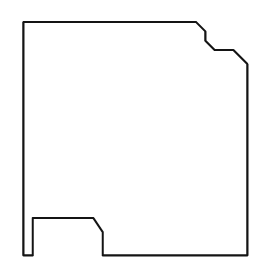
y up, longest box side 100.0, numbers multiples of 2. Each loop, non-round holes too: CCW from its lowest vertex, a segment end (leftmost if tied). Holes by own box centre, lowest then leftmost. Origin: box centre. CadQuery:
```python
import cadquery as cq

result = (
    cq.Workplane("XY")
    .moveTo(-48.0, -50.0)
    .lineTo(-44.0, -50.0)
    .lineTo(-44.0, -34.0)
    .lineTo(-18.0, -34.0)
    .lineTo(-14.0, -40.0)
    .lineTo(-14.0, -50.0)
    .lineTo(48.0, -50.0)
    .lineTo(48.0, 32.0)
    .lineTo(42.0, 38.0)
    .lineTo(34.0, 38.0)
    .lineTo(30.0, 42.0)
    .lineTo(30.0, 46.0)
    .lineTo(26.0, 50.0)
    .lineTo(-48.0, 50.0)
    .close()
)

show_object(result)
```